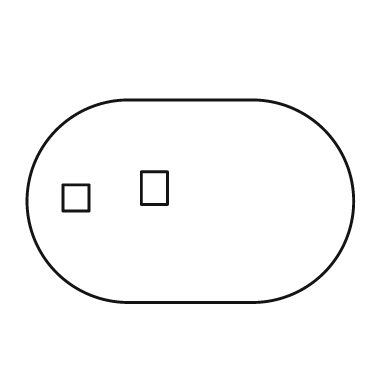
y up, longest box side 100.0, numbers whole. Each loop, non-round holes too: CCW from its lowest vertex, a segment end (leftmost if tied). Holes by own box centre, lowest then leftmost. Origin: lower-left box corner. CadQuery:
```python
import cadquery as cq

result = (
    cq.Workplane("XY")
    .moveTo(31.0, 0.0)
    .lineTo(69.0, 0.0)
    .threePointArc((100.0, 31.0), (69.0, 62.0))
    .lineTo(31.0, 62.0)
    .threePointArc((0.0, 31.0), (31.0, 0.0))
    .close()
    .moveTo(11.0, 28.0)
    .lineTo(19.0, 28.0)
    .lineTo(19.0, 36.0)
    .lineTo(11.0, 36.0)
    .close()
    .moveTo(35.0, 30.0)
    .lineTo(43.0, 30.0)
    .lineTo(43.0, 40.0)
    .lineTo(35.0, 40.0)
    .close()
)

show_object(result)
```